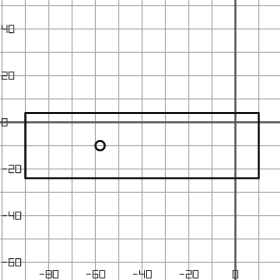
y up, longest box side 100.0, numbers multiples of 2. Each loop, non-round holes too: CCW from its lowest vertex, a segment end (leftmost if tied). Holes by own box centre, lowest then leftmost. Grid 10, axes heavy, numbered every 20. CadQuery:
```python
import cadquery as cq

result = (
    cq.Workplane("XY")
    .moveTo(-90.0, -24.0)
    .lineTo(10.0, -24.0)
    .lineTo(10.0, 4.0)
    .lineTo(-90.0, 4.0)
    .close()
    .moveTo(-58.0, -10.0)
    .circle(2.0)
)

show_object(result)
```